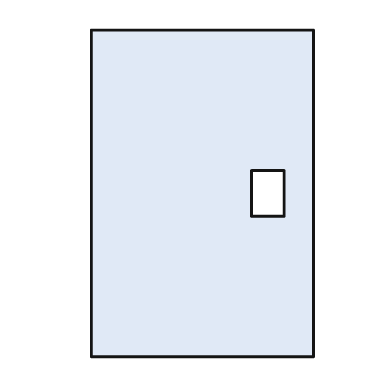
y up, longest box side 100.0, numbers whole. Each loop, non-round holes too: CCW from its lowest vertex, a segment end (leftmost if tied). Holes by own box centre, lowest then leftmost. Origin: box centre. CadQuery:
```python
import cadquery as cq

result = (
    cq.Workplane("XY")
    .moveTo(-34.0, -50.0)
    .lineTo(34.0, -50.0)
    .lineTo(34.0, 50.0)
    .lineTo(-34.0, 50.0)
    .close()
    .moveTo(15.0, -7.0)
    .lineTo(25.0, -7.0)
    .lineTo(25.0, 7.0)
    .lineTo(15.0, 7.0)
    .close()
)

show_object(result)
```